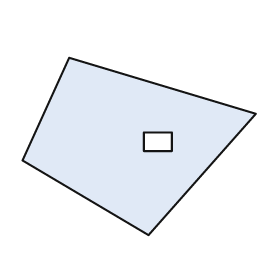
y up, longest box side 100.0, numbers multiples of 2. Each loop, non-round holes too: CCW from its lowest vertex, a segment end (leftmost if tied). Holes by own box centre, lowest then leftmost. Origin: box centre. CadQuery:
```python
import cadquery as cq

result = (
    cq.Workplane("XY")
    .moveTo(4.0, -38.0)
    .lineTo(50.0, 14.0)
    .lineTo(-30.0, 38.0)
    .lineTo(-50.0, -6.0)
    .close()
    .moveTo(2.0, -2.0)
    .lineTo(14.0, -2.0)
    .lineTo(14.0, 6.0)
    .lineTo(2.0, 6.0)
    .close()
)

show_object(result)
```